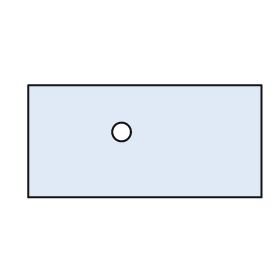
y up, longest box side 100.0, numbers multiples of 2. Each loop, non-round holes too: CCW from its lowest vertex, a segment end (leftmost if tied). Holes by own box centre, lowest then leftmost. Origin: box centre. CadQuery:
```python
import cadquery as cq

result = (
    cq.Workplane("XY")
    .moveTo(-50.0, -24.0)
    .lineTo(50.0, -24.0)
    .lineTo(50.0, 24.0)
    .lineTo(-50.0, 24.0)
    .close()
    .moveTo(-10.0, 4.0)
    .circle(4.0)
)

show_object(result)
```